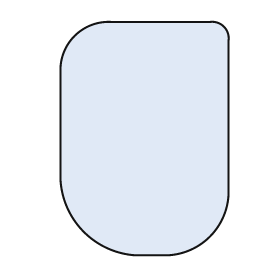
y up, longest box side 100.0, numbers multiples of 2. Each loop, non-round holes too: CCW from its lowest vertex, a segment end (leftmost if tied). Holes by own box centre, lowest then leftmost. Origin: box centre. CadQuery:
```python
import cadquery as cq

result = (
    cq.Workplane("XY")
    .moveTo(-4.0, -50.0)
    .lineTo(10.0, -50.0)
    .threePointArc((28.0, -42.0), (36.0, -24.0))
    .lineTo(36.0, 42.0)
    .threePointArc((34.0, 48.0), (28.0, 50.0))
    .lineTo(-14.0, 50.0)
    .threePointArc((-30.0, 44.0), (-36.0, 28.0))
    .lineTo(-36.0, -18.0)
    .threePointArc((-26.0, -40.0), (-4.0, -50.0))
    .close()
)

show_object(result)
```